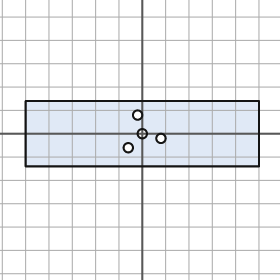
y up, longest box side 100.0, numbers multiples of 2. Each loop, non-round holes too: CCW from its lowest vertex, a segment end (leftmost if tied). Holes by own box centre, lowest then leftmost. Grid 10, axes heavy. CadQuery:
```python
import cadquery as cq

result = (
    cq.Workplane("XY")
    .moveTo(-50.0, -14.0)
    .lineTo(50.0, -14.0)
    .lineTo(50.0, 14.0)
    .lineTo(-50.0, 14.0)
    .close()
    .moveTo(-6.0, -6.0)
    .circle(2.0)
    .moveTo(8.0, -2.0)
    .circle(2.0)
    .moveTo(0.0, 0.0)
    .circle(2.0)
    .moveTo(-2.0, 8.0)
    .circle(2.0)
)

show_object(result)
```